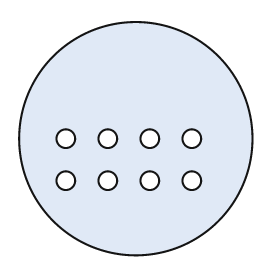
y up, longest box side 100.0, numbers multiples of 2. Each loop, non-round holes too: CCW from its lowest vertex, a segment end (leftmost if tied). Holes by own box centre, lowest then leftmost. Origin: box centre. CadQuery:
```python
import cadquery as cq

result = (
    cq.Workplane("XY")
    .moveTo(0.0, 0.0)
    .circle(50.0)
    .moveTo(-30.0, -18.0)
    .circle(4.0)
    .moveTo(-12.0, -18.0)
    .circle(4.0)
    .moveTo(6.0, -18.0)
    .circle(4.0)
    .moveTo(24.0, -18.0)
    .circle(4.0)
    .moveTo(-30.0, 0.0)
    .circle(4.0)
    .moveTo(-12.0, 0.0)
    .circle(4.0)
    .moveTo(6.0, 0.0)
    .circle(4.0)
    .moveTo(24.0, 0.0)
    .circle(4.0)
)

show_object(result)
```